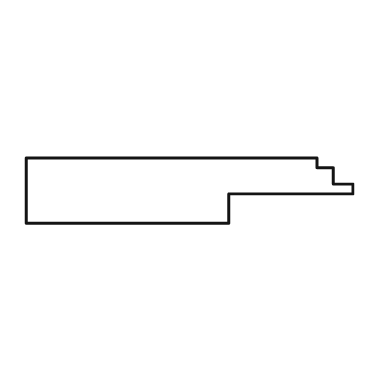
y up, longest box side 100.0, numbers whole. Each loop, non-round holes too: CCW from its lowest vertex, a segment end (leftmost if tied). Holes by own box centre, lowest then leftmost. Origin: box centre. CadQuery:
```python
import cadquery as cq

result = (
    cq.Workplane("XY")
    .moveTo(-50.0, -10.0)
    .lineTo(12.0, -10.0)
    .lineTo(12.0, -1.0)
    .lineTo(50.0, -1.0)
    .lineTo(50.0, 2.0)
    .lineTo(44.0, 2.0)
    .lineTo(44.0, 7.0)
    .lineTo(39.0, 7.0)
    .lineTo(39.0, 10.0)
    .lineTo(-50.0, 10.0)
    .close()
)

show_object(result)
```